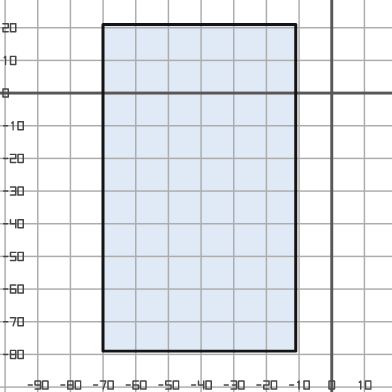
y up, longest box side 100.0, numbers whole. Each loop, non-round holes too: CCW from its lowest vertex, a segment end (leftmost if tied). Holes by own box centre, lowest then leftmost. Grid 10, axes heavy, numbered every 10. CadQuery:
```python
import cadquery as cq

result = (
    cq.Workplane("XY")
    .moveTo(-70.0, -79.0)
    .lineTo(-11.0, -79.0)
    .lineTo(-11.0, 21.0)
    .lineTo(-70.0, 21.0)
    .close()
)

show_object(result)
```